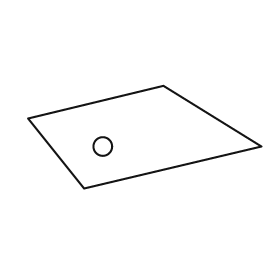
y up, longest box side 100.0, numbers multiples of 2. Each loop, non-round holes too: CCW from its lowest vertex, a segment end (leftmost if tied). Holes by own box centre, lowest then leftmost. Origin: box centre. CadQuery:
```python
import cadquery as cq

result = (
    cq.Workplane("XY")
    .moveTo(-26.0, -22.0)
    .lineTo(50.0, -4.0)
    .lineTo(8.0, 22.0)
    .lineTo(-50.0, 8.0)
    .close()
    .moveTo(-18.0, -4.0)
    .circle(4.0)
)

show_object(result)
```